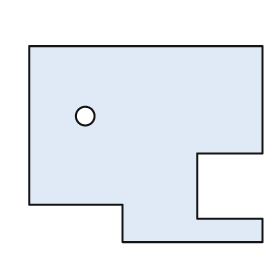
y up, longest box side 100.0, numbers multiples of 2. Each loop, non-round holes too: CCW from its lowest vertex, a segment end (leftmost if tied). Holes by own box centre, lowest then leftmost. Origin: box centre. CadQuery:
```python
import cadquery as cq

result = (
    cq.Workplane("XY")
    .moveTo(-10.0, -42.0)
    .lineTo(50.0, -42.0)
    .lineTo(50.0, -32.0)
    .lineTo(22.0, -32.0)
    .lineTo(22.0, -4.0)
    .lineTo(50.0, -4.0)
    .lineTo(50.0, 42.0)
    .lineTo(-50.0, 42.0)
    .lineTo(-50.0, -26.0)
    .lineTo(-10.0, -26.0)
    .close()
    .moveTo(-26.0, 12.0)
    .circle(4.0)
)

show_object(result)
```